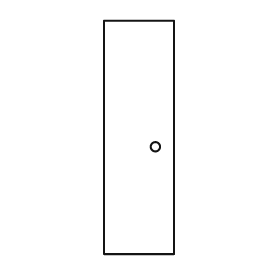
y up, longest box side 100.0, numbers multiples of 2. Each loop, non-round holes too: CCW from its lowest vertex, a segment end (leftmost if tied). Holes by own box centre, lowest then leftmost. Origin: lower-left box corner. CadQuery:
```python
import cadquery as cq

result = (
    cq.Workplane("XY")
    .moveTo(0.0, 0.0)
    .lineTo(30.0, 0.0)
    .lineTo(30.0, 100.0)
    .lineTo(0.0, 100.0)
    .close()
    .moveTo(22.0, 46.0)
    .circle(2.0)
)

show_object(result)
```